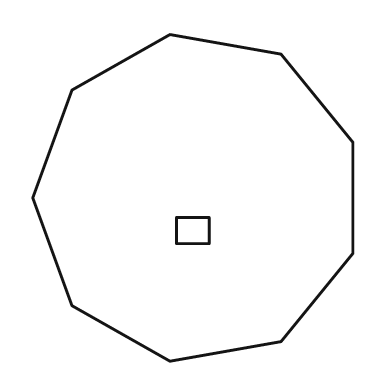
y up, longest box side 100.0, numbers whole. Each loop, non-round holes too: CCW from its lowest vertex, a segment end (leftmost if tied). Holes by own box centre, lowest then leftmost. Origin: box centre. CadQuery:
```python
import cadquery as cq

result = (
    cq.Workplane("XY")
    .moveTo(-7.0, -50.0)
    .lineTo(27.0, -44.0)
    .lineTo(49.0, -17.0)
    .lineTo(49.0, 17.0)
    .lineTo(27.0, 44.0)
    .lineTo(-7.0, 50.0)
    .lineTo(-37.0, 33.0)
    .lineTo(-49.0, 0.0)
    .lineTo(-37.0, -33.0)
    .close()
    .moveTo(-5.0, -14.0)
    .lineTo(5.0, -14.0)
    .lineTo(5.0, -6.0)
    .lineTo(-5.0, -6.0)
    .close()
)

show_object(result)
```